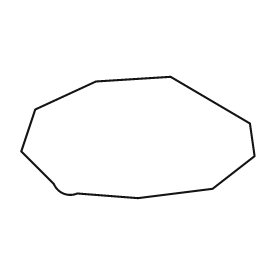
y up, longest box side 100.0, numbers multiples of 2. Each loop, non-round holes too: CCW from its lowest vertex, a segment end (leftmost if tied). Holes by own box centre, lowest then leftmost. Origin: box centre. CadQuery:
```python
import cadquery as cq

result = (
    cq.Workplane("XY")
    .moveTo(0.0, -26.0)
    .lineTo(32.0, -22.0)
    .lineTo(50.0, -8.0)
    .lineTo(48.0, 6.0)
    .lineTo(14.0, 26.0)
    .lineTo(-18.0, 24.0)
    .lineTo(-44.0, 12.0)
    .lineTo(-50.0, -6.0)
    .lineTo(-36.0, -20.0)
    .threePointArc((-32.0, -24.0), (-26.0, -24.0))
    .close()
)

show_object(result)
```